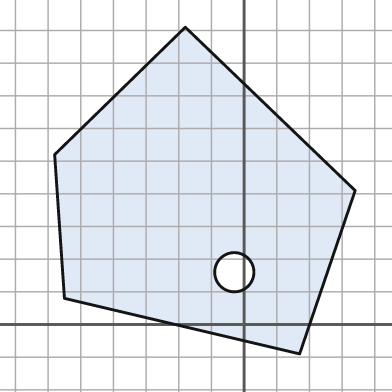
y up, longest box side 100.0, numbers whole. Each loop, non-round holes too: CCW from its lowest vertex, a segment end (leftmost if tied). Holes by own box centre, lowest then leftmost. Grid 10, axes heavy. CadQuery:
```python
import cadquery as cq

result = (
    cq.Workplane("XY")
    .moveTo(17.0, -9.0)
    .lineTo(34.0, 41.0)
    .lineTo(-18.0, 91.0)
    .lineTo(-58.0, 52.0)
    .lineTo(-55.0, 8.0)
    .close()
    .moveTo(-3.0, 16.0)
    .circle(6.0)
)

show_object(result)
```